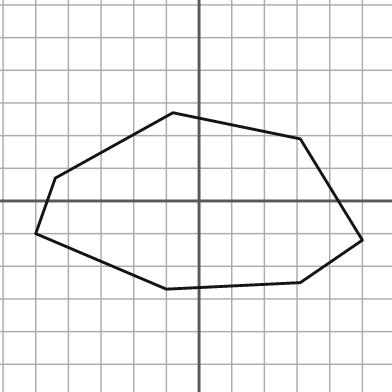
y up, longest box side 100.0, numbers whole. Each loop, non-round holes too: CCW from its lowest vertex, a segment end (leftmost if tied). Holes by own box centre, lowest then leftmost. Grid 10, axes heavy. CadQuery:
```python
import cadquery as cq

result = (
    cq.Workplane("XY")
    .moveTo(-10.0, -27.0)
    .lineTo(31.0, -25.0)
    .lineTo(50.0, -12.0)
    .lineTo(31.0, 19.0)
    .lineTo(-8.0, 27.0)
    .lineTo(-44.0, 7.0)
    .lineTo(-50.0, -10.0)
    .close()
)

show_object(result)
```